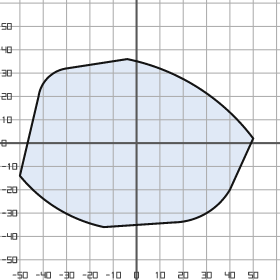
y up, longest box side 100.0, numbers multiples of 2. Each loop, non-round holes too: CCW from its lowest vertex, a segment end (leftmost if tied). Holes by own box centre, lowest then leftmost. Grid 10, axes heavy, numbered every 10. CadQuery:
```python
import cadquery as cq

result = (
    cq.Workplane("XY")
    .moveTo(-14.0, -36.0)
    .lineTo(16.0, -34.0)
    .threePointArc((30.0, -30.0), (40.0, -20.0))
    .lineTo(50.0, 2.0)
    .threePointArc((26.0, 24.0), (-4.0, 36.0))
    .lineTo(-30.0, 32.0)
    .threePointArc((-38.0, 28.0), (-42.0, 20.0))
    .lineTo(-50.0, -14.0)
    .threePointArc((-34.0, -28.0), (-14.0, -36.0))
    .close()
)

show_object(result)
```